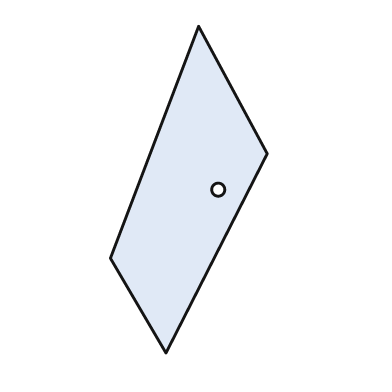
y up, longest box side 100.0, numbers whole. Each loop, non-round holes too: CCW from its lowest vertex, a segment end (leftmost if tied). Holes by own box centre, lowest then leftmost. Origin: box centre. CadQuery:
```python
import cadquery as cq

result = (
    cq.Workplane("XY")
    .moveTo(-7.0, -50.0)
    .lineTo(24.0, 11.0)
    .lineTo(3.0, 50.0)
    .lineTo(-24.0, -21.0)
    .close()
    .moveTo(9.0, 0.0)
    .circle(2.0)
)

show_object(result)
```